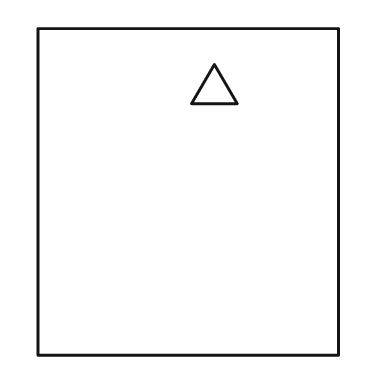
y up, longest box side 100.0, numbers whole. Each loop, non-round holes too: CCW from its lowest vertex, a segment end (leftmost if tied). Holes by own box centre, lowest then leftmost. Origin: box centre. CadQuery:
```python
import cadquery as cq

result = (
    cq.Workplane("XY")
    .moveTo(-46.0, -50.0)
    .lineTo(46.0, -50.0)
    .lineTo(46.0, 50.0)
    .lineTo(-46.0, 50.0)
    .close()
    .moveTo(1.0, 27.0)
    .lineTo(15.0, 27.0)
    .lineTo(8.0, 39.0)
    .close()
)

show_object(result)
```